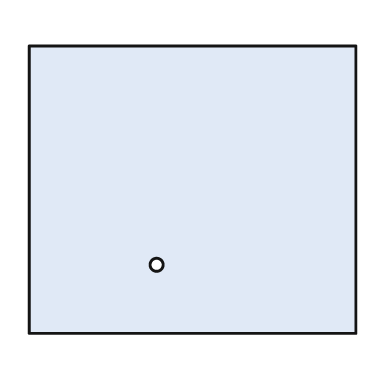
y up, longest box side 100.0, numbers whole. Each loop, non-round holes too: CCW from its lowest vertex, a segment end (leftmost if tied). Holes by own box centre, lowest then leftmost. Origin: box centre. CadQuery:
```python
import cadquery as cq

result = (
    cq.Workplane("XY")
    .moveTo(-50.0, -44.0)
    .lineTo(50.0, -44.0)
    .lineTo(50.0, 44.0)
    .lineTo(-50.0, 44.0)
    .close()
    .moveTo(-11.0, -23.0)
    .circle(2.0)
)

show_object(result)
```